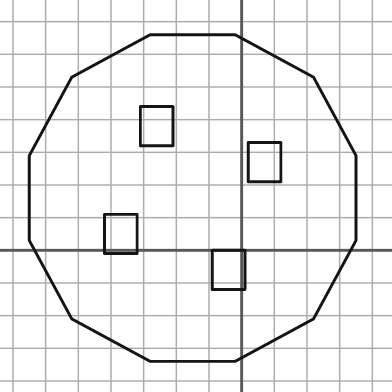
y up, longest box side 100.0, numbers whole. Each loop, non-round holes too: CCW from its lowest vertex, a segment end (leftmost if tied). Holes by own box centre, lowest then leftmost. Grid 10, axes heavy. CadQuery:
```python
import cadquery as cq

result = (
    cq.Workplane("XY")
    .moveTo(-28.0, -34.0)
    .lineTo(-2.0, -34.0)
    .lineTo(22.0, -21.0)
    .lineTo(35.0, 3.0)
    .lineTo(35.0, 29.0)
    .lineTo(22.0, 53.0)
    .lineTo(-2.0, 66.0)
    .lineTo(-28.0, 66.0)
    .lineTo(-52.0, 53.0)
    .lineTo(-65.0, 29.0)
    .lineTo(-65.0, 3.0)
    .lineTo(-52.0, -21.0)
    .close()
    .moveTo(-9.0, -12.0)
    .lineTo(1.0, -12.0)
    .lineTo(1.0, 0.0)
    .lineTo(-9.0, 0.0)
    .close()
    .moveTo(-42.0, -1.0)
    .lineTo(-32.0, -1.0)
    .lineTo(-32.0, 11.0)
    .lineTo(-42.0, 11.0)
    .close()
    .moveTo(2.0, 21.0)
    .lineTo(12.0, 21.0)
    .lineTo(12.0, 33.0)
    .lineTo(2.0, 33.0)
    .close()
    .moveTo(-31.0, 32.0)
    .lineTo(-21.0, 32.0)
    .lineTo(-21.0, 44.0)
    .lineTo(-31.0, 44.0)
    .close()
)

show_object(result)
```